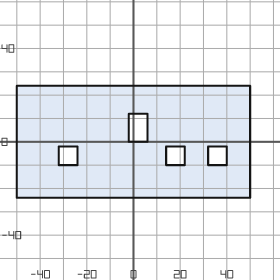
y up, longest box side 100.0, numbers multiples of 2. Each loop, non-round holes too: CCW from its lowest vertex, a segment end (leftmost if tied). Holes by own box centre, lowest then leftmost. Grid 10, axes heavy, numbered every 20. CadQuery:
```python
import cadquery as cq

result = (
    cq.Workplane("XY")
    .moveTo(-50.0, -24.0)
    .lineTo(50.0, -24.0)
    .lineTo(50.0, 24.0)
    .lineTo(-50.0, 24.0)
    .close()
    .moveTo(-32.0, -10.0)
    .lineTo(-24.0, -10.0)
    .lineTo(-24.0, -2.0)
    .lineTo(-32.0, -2.0)
    .close()
    .moveTo(14.0, -10.0)
    .lineTo(22.0, -10.0)
    .lineTo(22.0, -2.0)
    .lineTo(14.0, -2.0)
    .close()
    .moveTo(32.0, -10.0)
    .lineTo(40.0, -10.0)
    .lineTo(40.0, -2.0)
    .lineTo(32.0, -2.0)
    .close()
    .moveTo(-2.0, 0.0)
    .lineTo(6.0, 0.0)
    .lineTo(6.0, 12.0)
    .lineTo(-2.0, 12.0)
    .close()
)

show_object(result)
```